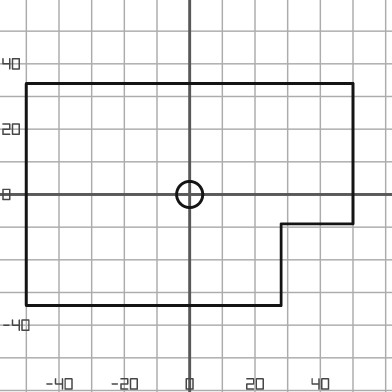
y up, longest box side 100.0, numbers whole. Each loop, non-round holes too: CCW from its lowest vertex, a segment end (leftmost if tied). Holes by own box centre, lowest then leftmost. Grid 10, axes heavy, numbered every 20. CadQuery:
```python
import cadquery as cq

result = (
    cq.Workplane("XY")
    .moveTo(-50.0, -34.0)
    .lineTo(28.0, -34.0)
    .lineTo(28.0, -9.0)
    .lineTo(50.0, -9.0)
    .lineTo(50.0, 34.0)
    .lineTo(-50.0, 34.0)
    .close()
    .moveTo(0.0, 0.0)
    .circle(4.0)
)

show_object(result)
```